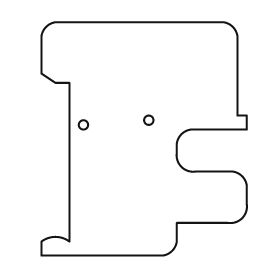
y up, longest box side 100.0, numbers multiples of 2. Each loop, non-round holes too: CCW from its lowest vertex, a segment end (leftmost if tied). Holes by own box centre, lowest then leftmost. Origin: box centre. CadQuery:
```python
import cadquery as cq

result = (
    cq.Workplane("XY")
    .moveTo(-44.0, -50.0)
    .lineTo(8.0, -50.0)
    .threePointArc((12.0, -48.0), (14.0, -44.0))
    .lineTo(14.0, -36.0)
    .lineTo(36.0, -36.0)
    .threePointArc((42.0, -34.0), (44.0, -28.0))
    .lineTo(44.0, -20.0)
    .threePointArc((42.0, -16.0), (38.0, -14.0))
    .lineTo(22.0, -14.0)
    .threePointArc((16.0, -12.0), (14.0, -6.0))
    .lineTo(14.0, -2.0)
    .threePointArc((16.0, 2.0), (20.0, 4.0))
    .lineTo(44.0, 4.0)
    .lineTo(44.0, 10.0)
    .lineTo(40.0, 10.0)
    .lineTo(40.0, 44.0)
    .threePointArc((38.0, 48.0), (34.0, 50.0))
    .lineTo(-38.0, 50.0)
    .threePointArc((-42.0, 48.0), (-44.0, 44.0))
    .lineTo(-44.0, 28.0)
    .lineTo(-38.0, 24.0)
    .lineTo(-32.0, 24.0)
    .lineTo(-32.0, -44.0)
    .threePointArc((-38.0, -42.0), (-44.0, -44.0))
    .close()
    .moveTo(-26.0, 6.0)
    .circle(2.0)
    .moveTo(2.0, 8.0)
    .circle(2.0)
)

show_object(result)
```